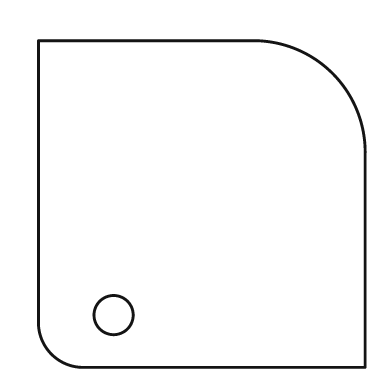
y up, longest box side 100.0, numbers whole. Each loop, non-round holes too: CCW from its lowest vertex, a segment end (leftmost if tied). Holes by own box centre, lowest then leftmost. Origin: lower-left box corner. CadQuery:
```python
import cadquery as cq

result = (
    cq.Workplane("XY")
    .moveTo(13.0, 0.0)
    .lineTo(100.0, 0.0)
    .lineTo(100.0, 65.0)
    .threePointArc((90.0, 90.0), (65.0, 100.0))
    .lineTo(0.0, 100.0)
    .lineTo(0.0, 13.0)
    .threePointArc((4.0, 4.0), (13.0, 0.0))
    .close()
    .moveTo(23.0, 16.0)
    .circle(6.0)
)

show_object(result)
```